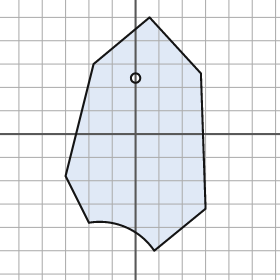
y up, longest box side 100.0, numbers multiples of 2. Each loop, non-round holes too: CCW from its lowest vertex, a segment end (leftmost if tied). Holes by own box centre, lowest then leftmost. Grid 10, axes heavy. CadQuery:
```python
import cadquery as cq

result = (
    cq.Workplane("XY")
    .moveTo(8.0, -50.0)
    .lineTo(30.0, -32.0)
    .lineTo(28.0, 26.0)
    .lineTo(6.0, 50.0)
    .lineTo(-18.0, 30.0)
    .lineTo(-30.0, -18.0)
    .lineTo(-20.0, -38.0)
    .threePointArc((-4.0, -40.0), (8.0, -50.0))
    .close()
    .moveTo(0.0, 24.0)
    .circle(2.0)
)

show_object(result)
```